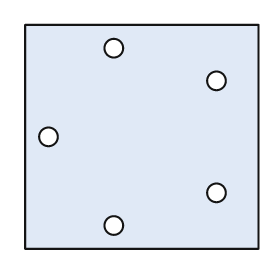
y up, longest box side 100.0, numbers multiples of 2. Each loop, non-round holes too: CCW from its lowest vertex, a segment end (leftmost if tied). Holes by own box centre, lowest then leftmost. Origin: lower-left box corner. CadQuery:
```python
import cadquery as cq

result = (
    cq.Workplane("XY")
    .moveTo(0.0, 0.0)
    .lineTo(100.0, 0.0)
    .lineTo(100.0, 96.0)
    .lineTo(0.0, 96.0)
    .close()
    .moveTo(38.0, 10.0)
    .circle(4.0)
    .moveTo(82.0, 24.0)
    .circle(4.0)
    .moveTo(10.0, 48.0)
    .circle(4.0)
    .moveTo(82.0, 72.0)
    .circle(4.0)
    .moveTo(38.0, 86.0)
    .circle(4.0)
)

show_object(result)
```